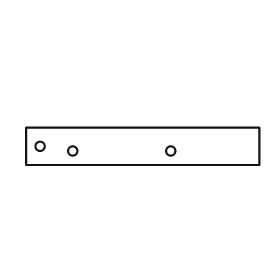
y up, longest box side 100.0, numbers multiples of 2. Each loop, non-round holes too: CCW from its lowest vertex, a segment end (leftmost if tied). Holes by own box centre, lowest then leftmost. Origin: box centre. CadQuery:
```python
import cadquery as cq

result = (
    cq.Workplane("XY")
    .moveTo(-50.0, -8.0)
    .lineTo(50.0, -8.0)
    .lineTo(50.0, 8.0)
    .lineTo(-50.0, 8.0)
    .close()
    .moveTo(-30.0, -2.0)
    .circle(2.0)
    .moveTo(12.0, -2.0)
    .circle(2.0)
    .moveTo(-44.0, 0.0)
    .circle(2.0)
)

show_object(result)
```